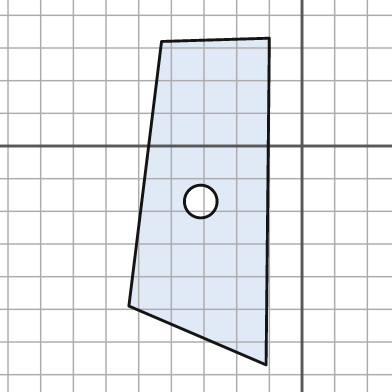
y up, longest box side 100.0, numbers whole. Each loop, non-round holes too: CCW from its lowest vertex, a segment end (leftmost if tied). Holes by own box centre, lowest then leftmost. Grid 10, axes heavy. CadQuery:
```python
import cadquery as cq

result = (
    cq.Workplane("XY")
    .moveTo(-11.0, -67.0)
    .lineTo(-10.0, 33.0)
    .lineTo(-43.0, 32.0)
    .lineTo(-53.0, -49.0)
    .close()
    .moveTo(-31.0, -17.0)
    .circle(5.0)
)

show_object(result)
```